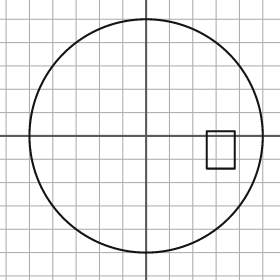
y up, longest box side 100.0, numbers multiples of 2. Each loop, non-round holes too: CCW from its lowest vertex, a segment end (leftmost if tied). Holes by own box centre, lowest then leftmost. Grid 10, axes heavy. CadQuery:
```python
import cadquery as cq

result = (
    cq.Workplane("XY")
    .moveTo(0.0, 0.0)
    .circle(50.0)
    .moveTo(26.0, -14.0)
    .lineTo(38.0, -14.0)
    .lineTo(38.0, 2.0)
    .lineTo(26.0, 2.0)
    .close()
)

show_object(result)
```